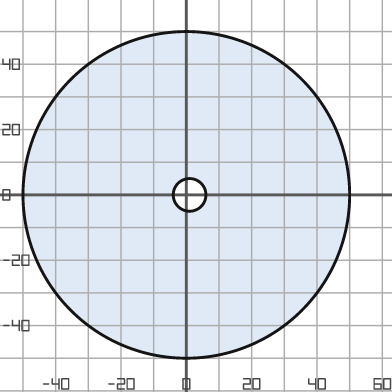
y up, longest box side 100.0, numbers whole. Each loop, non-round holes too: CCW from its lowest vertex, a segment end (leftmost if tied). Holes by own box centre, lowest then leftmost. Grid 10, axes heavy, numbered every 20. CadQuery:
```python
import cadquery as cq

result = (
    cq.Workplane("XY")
    .moveTo(0.0, 0.0)
    .circle(50.0)
    .moveTo(1.0, 0.0)
    .circle(5.0)
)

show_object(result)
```